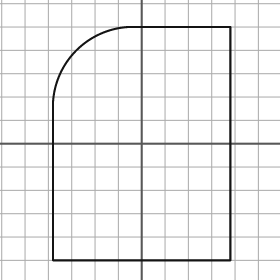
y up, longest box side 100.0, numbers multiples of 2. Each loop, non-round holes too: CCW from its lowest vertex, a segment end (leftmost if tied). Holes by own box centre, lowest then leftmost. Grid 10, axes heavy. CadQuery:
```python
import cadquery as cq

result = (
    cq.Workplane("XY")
    .moveTo(-38.0, -50.0)
    .lineTo(38.0, -50.0)
    .lineTo(38.0, 50.0)
    .lineTo(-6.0, 50.0)
    .threePointArc((-28.0, 40.0), (-38.0, 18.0))
    .close()
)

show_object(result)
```